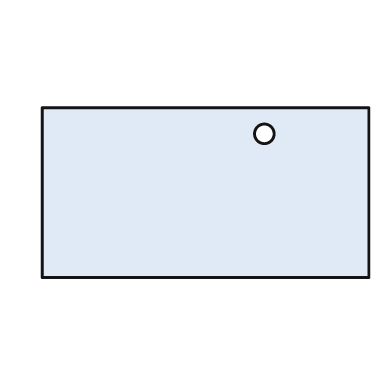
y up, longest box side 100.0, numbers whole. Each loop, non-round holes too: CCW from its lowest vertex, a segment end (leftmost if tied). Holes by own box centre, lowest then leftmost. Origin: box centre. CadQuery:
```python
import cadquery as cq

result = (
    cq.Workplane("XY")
    .moveTo(-50.0, -26.0)
    .lineTo(50.0, -26.0)
    .lineTo(50.0, 26.0)
    .lineTo(-50.0, 26.0)
    .close()
    .moveTo(18.0, 18.0)
    .circle(3.0)
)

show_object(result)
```